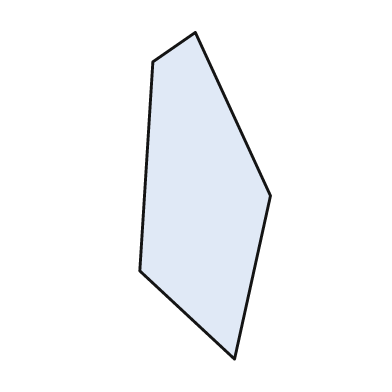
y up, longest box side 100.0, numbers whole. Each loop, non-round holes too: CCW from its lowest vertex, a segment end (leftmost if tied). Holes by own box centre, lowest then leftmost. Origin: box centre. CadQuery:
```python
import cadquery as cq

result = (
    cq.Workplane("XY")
    .moveTo(9.0, -50.0)
    .lineTo(20.0, 0.0)
    .lineTo(-3.0, 50.0)
    .lineTo(-16.0, 41.0)
    .lineTo(-20.0, -23.0)
    .close()
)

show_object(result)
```